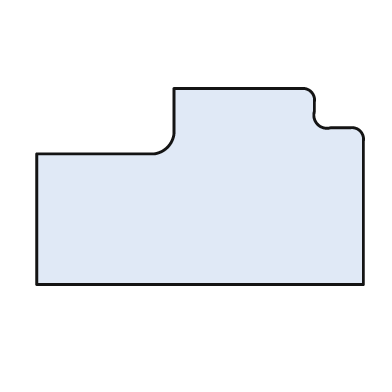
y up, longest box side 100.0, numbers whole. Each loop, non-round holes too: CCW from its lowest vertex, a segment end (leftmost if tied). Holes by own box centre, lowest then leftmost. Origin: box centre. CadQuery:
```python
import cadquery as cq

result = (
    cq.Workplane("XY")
    .moveTo(-50.0, -30.0)
    .lineTo(50.0, -30.0)
    .lineTo(50.0, 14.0)
    .threePointArc((49.0, 17.0), (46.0, 18.0))
    .lineTo(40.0, 18.0)
    .threePointArc((36.0, 19.0), (35.0, 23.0))
    .lineTo(35.0, 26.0)
    .threePointArc((34.0, 29.0), (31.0, 30.0))
    .lineTo(-8.0, 30.0)
    .lineTo(-8.0, 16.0)
    .threePointArc((-10.0, 12.0), (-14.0, 10.0))
    .lineTo(-50.0, 10.0)
    .close()
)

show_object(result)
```